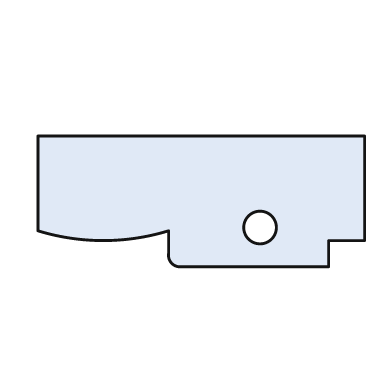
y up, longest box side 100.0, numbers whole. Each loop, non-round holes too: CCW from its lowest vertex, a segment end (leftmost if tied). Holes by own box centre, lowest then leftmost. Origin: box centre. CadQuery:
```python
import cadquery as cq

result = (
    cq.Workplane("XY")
    .moveTo(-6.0, -20.0)
    .lineTo(39.0, -20.0)
    .lineTo(39.0, -12.0)
    .lineTo(50.0, -12.0)
    .lineTo(50.0, 20.0)
    .lineTo(-50.0, 20.0)
    .lineTo(-50.0, -9.0)
    .threePointArc((-30.0, -12.0), (-10.0, -9.0))
    .lineTo(-10.0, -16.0)
    .threePointArc((-9.0, -19.0), (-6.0, -20.0))
    .close()
    .moveTo(18.0, -8.0)
    .circle(5.0)
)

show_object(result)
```